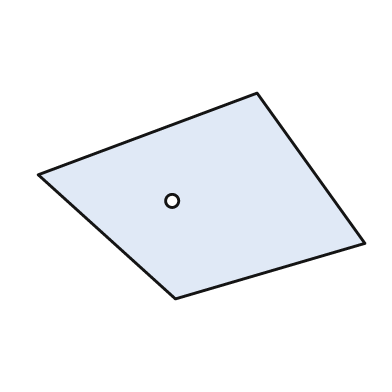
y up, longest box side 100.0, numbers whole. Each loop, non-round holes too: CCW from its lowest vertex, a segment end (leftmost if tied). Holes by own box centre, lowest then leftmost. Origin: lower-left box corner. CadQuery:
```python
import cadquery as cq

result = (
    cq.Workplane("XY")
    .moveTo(42.0, 0.0)
    .lineTo(100.0, 17.0)
    .lineTo(67.0, 63.0)
    .lineTo(0.0, 38.0)
    .close()
    .moveTo(41.0, 30.0)
    .circle(2.0)
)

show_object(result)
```